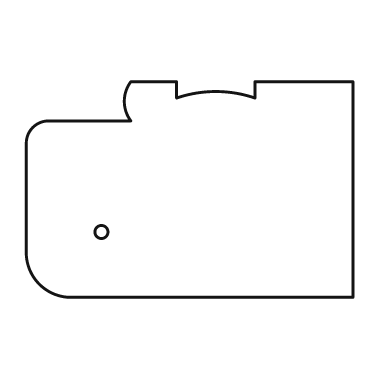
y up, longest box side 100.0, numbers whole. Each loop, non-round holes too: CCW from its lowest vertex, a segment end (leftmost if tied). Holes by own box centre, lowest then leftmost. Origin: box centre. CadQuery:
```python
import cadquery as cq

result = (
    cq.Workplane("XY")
    .moveTo(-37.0, -33.0)
    .lineTo(50.0, -33.0)
    .lineTo(50.0, 33.0)
    .lineTo(20.0, 33.0)
    .lineTo(20.0, 28.0)
    .threePointArc((8.0, 30.0), (-4.0, 28.0))
    .lineTo(-4.0, 33.0)
    .lineTo(-18.0, 33.0)
    .threePointArc((-20.0, 27.0), (-18.0, 21.0))
    .lineTo(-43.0, 21.0)
    .threePointArc((-48.0, 19.0), (-50.0, 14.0))
    .lineTo(-50.0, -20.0)
    .threePointArc((-46.0, -29.0), (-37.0, -33.0))
    .close()
    .moveTo(-27.0, -13.0)
    .circle(2.0)
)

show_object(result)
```